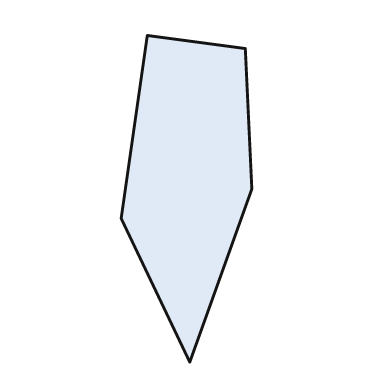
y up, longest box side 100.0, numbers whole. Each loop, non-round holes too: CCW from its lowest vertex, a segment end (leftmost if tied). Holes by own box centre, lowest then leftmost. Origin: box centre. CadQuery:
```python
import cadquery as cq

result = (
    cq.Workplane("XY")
    .moveTo(1.0, -50.0)
    .lineTo(20.0, 3.0)
    .lineTo(18.0, 46.0)
    .lineTo(-12.0, 50.0)
    .lineTo(-20.0, -6.0)
    .close()
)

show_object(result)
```